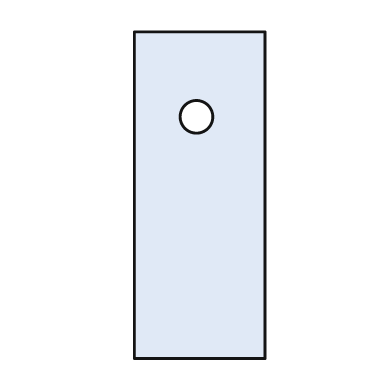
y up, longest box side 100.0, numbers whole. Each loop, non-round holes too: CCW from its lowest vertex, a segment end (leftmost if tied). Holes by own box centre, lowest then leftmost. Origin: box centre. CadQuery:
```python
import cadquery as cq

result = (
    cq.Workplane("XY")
    .moveTo(-20.0, -50.0)
    .lineTo(20.0, -50.0)
    .lineTo(20.0, 50.0)
    .lineTo(-20.0, 50.0)
    .close()
    .moveTo(-1.0, 24.0)
    .circle(5.0)
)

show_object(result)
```